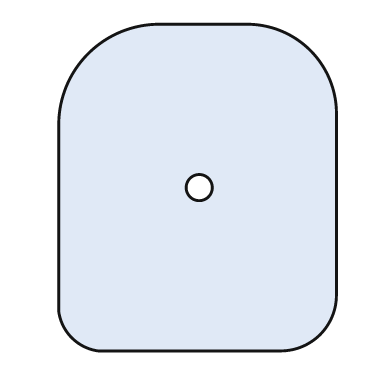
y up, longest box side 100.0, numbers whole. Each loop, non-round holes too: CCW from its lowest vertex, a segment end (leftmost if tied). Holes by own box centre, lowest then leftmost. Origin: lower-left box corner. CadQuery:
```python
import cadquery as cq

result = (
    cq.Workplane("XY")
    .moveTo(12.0, 0.0)
    .lineTo(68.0, 0.0)
    .threePointArc((80.0, 5.0), (85.0, 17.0))
    .lineTo(85.0, 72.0)
    .threePointArc((77.0, 92.0), (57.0, 100.0))
    .lineTo(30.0, 100.0)
    .threePointArc((9.0, 91.0), (0.0, 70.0))
    .lineTo(0.0, 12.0)
    .threePointArc((4.0, 4.0), (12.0, 0.0))
    .close()
    .moveTo(43.0, 50.0)
    .circle(4.0)
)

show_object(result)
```